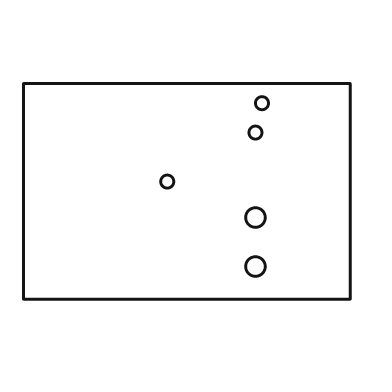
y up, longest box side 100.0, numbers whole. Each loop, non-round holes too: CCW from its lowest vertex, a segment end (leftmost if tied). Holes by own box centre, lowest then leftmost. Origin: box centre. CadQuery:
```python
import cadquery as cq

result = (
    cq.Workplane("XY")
    .moveTo(-50.0, -33.0)
    .lineTo(50.0, -33.0)
    .lineTo(50.0, 33.0)
    .lineTo(-50.0, 33.0)
    .close()
    .moveTo(21.0, -23.0)
    .circle(3.0)
    .moveTo(21.0, -8.0)
    .circle(3.0)
    .moveTo(-6.0, 3.0)
    .circle(2.0)
    .moveTo(21.0, 18.0)
    .circle(2.0)
    .moveTo(23.0, 27.0)
    .circle(2.0)
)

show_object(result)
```